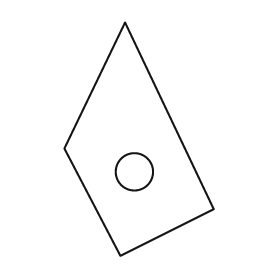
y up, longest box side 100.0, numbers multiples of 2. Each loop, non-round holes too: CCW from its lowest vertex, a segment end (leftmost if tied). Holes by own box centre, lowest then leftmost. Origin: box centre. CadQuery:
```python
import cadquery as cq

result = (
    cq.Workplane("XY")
    .moveTo(-8.0, -50.0)
    .lineTo(32.0, -30.0)
    .lineTo(-6.0, 50.0)
    .lineTo(-32.0, -4.0)
    .close()
    .moveTo(-2.0, -14.0)
    .circle(8.0)
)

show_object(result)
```